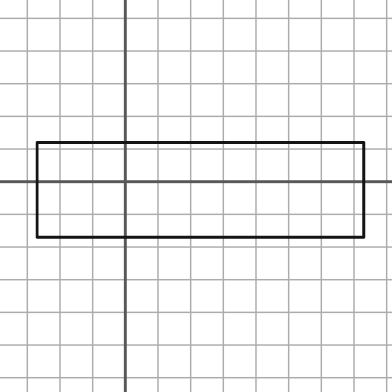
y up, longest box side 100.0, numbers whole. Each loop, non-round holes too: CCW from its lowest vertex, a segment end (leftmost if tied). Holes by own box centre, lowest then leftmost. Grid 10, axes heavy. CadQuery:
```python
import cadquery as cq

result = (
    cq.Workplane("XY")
    .moveTo(-27.0, -17.0)
    .lineTo(73.0, -17.0)
    .lineTo(73.0, 12.0)
    .lineTo(-27.0, 12.0)
    .close()
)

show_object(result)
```